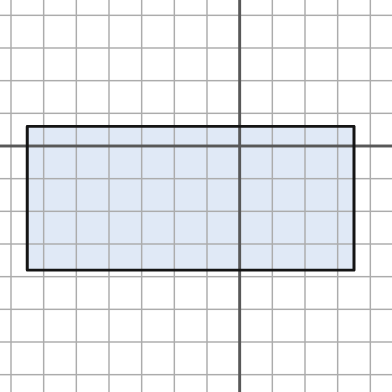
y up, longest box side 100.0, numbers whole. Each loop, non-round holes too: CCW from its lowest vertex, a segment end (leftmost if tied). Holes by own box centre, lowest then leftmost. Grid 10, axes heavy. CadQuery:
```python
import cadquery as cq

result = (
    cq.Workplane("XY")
    .moveTo(-65.0, -38.0)
    .lineTo(35.0, -38.0)
    .lineTo(35.0, 6.0)
    .lineTo(-65.0, 6.0)
    .close()
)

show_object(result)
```